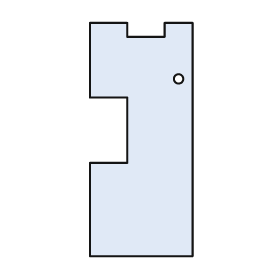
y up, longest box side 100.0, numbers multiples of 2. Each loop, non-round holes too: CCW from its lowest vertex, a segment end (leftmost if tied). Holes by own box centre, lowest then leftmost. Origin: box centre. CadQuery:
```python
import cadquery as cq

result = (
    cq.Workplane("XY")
    .moveTo(-22.0, -50.0)
    .lineTo(22.0, -50.0)
    .lineTo(22.0, 50.0)
    .lineTo(10.0, 50.0)
    .lineTo(10.0, 44.0)
    .lineTo(-6.0, 44.0)
    .lineTo(-6.0, 50.0)
    .lineTo(-22.0, 50.0)
    .lineTo(-22.0, 18.0)
    .lineTo(-6.0, 18.0)
    .lineTo(-6.0, -10.0)
    .lineTo(-22.0, -10.0)
    .close()
    .moveTo(16.0, 26.0)
    .circle(2.0)
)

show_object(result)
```